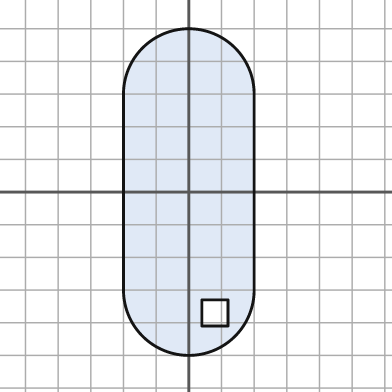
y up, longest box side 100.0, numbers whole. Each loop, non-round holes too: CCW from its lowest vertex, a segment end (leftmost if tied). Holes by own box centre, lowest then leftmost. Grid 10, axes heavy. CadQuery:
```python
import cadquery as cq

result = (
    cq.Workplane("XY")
    .moveTo(-20.0, -30.0)
    .threePointArc((0.0, -50.0), (20.0, -30.0))
    .lineTo(20.0, 30.0)
    .threePointArc((0.0, 50.0), (-20.0, 30.0))
    .close()
    .moveTo(4.0, -41.0)
    .lineTo(12.0, -41.0)
    .lineTo(12.0, -33.0)
    .lineTo(4.0, -33.0)
    .close()
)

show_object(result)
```